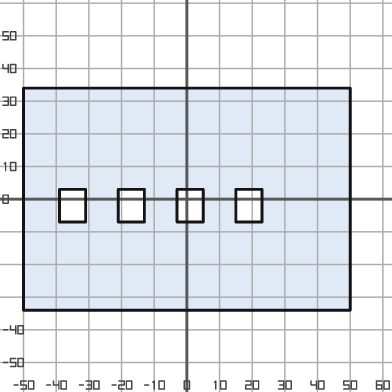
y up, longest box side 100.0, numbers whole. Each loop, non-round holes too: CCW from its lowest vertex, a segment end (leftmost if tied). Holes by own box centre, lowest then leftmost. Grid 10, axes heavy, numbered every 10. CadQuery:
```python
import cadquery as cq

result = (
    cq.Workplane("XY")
    .moveTo(-50.0, -34.0)
    .lineTo(50.0, -34.0)
    .lineTo(50.0, 34.0)
    .lineTo(-50.0, 34.0)
    .close()
    .moveTo(-39.0, -7.0)
    .lineTo(-31.0, -7.0)
    .lineTo(-31.0, 3.0)
    .lineTo(-39.0, 3.0)
    .close()
    .moveTo(-21.0, -7.0)
    .lineTo(-13.0, -7.0)
    .lineTo(-13.0, 3.0)
    .lineTo(-21.0, 3.0)
    .close()
    .moveTo(-3.0, -7.0)
    .lineTo(5.0, -7.0)
    .lineTo(5.0, 3.0)
    .lineTo(-3.0, 3.0)
    .close()
    .moveTo(15.0, -7.0)
    .lineTo(23.0, -7.0)
    .lineTo(23.0, 3.0)
    .lineTo(15.0, 3.0)
    .close()
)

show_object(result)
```